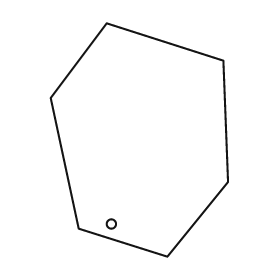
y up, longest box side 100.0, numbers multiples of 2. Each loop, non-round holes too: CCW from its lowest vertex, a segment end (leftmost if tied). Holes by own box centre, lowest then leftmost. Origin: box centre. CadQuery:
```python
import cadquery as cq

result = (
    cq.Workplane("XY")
    .moveTo(12.0, -50.0)
    .lineTo(38.0, -18.0)
    .lineTo(36.0, 34.0)
    .lineTo(-14.0, 50.0)
    .lineTo(-38.0, 18.0)
    .lineTo(-26.0, -38.0)
    .close()
    .moveTo(-12.0, -36.0)
    .circle(2.0)
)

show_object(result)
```